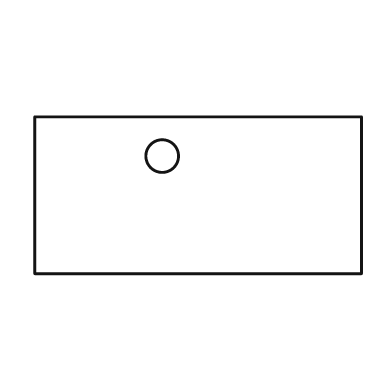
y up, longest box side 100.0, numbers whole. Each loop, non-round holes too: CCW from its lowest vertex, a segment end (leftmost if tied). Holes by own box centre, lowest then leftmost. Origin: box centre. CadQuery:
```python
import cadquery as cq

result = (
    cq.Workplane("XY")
    .moveTo(-50.0, -24.0)
    .lineTo(50.0, -24.0)
    .lineTo(50.0, 24.0)
    .lineTo(-50.0, 24.0)
    .close()
    .moveTo(-11.0, 12.0)
    .circle(5.0)
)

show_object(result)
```